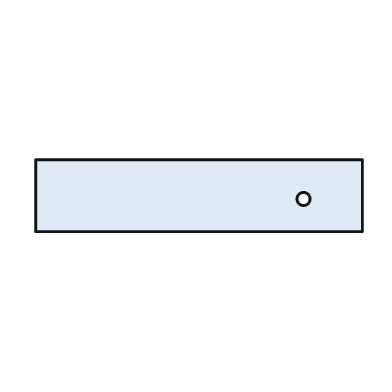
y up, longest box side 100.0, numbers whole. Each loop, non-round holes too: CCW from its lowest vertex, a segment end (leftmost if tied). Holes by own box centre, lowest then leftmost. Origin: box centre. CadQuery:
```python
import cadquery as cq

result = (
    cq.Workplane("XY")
    .moveTo(-50.0, -11.0)
    .lineTo(50.0, -11.0)
    .lineTo(50.0, 11.0)
    .lineTo(-50.0, 11.0)
    .close()
    .moveTo(32.0, -1.0)
    .circle(2.0)
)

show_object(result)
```